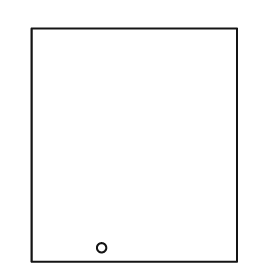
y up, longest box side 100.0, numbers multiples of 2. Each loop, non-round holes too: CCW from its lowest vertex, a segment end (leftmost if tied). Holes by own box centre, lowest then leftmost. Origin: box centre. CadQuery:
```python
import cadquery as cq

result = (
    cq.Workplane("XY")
    .moveTo(-44.0, -50.0)
    .lineTo(44.0, -50.0)
    .lineTo(44.0, 50.0)
    .lineTo(-44.0, 50.0)
    .close()
    .moveTo(-14.0, -44.0)
    .circle(2.0)
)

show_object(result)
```